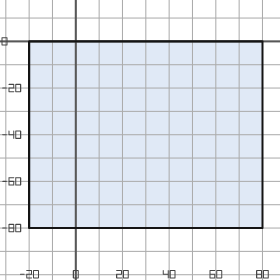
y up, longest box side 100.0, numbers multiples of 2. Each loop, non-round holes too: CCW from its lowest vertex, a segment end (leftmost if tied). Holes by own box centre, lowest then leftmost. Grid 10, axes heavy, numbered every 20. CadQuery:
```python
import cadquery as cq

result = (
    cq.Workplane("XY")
    .moveTo(-20.0, -80.0)
    .lineTo(80.0, -80.0)
    .lineTo(80.0, 0.0)
    .lineTo(-20.0, 0.0)
    .close()
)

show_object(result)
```